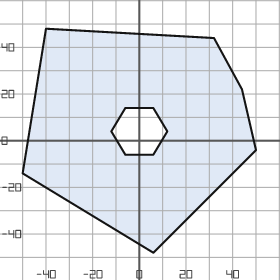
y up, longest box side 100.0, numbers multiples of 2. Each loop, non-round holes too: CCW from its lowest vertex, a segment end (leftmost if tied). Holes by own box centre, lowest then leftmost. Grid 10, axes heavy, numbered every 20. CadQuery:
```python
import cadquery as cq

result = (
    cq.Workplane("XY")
    .moveTo(6.0, -48.0)
    .lineTo(50.0, -4.0)
    .lineTo(44.0, 22.0)
    .lineTo(32.0, 44.0)
    .lineTo(-40.0, 48.0)
    .lineTo(-50.0, -14.0)
    .close()
    .moveTo(-6.0, -6.0)
    .lineTo(6.0, -6.0)
    .lineTo(12.0, 4.0)
    .lineTo(6.0, 14.0)
    .lineTo(-6.0, 14.0)
    .lineTo(-12.0, 4.0)
    .close()
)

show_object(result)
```